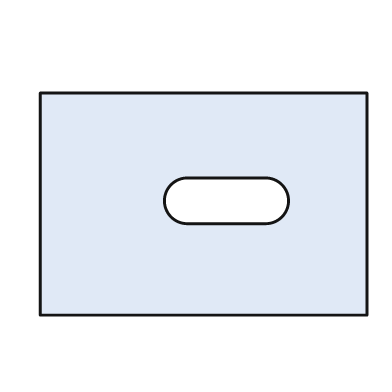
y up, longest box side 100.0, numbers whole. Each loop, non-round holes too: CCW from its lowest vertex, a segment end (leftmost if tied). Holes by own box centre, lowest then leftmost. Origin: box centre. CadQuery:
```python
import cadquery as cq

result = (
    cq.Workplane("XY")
    .moveTo(-50.0, -34.0)
    .lineTo(50.0, -34.0)
    .lineTo(50.0, 34.0)
    .lineTo(-50.0, 34.0)
    .close()
    .moveTo(-5.0, -6.0)
    .lineTo(19.0, -6.0)
    .threePointArc((26.0, 1.0), (19.0, 8.0))
    .lineTo(-5.0, 8.0)
    .threePointArc((-12.0, 1.0), (-5.0, -6.0))
    .close()
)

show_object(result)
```